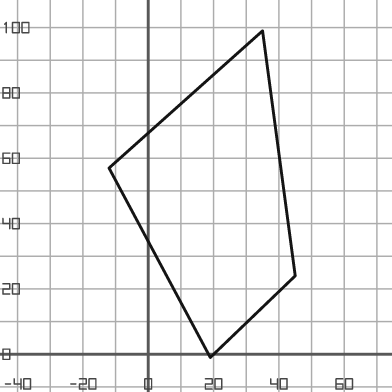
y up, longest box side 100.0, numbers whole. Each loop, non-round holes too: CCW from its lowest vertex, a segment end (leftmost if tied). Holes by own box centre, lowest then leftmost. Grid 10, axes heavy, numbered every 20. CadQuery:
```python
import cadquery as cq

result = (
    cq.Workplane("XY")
    .moveTo(19.0, -1.0)
    .lineTo(45.0, 24.0)
    .lineTo(35.0, 99.0)
    .lineTo(-12.0, 57.0)
    .close()
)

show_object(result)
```